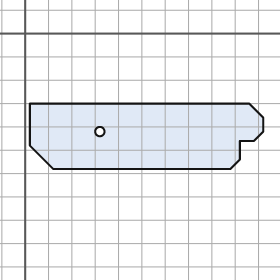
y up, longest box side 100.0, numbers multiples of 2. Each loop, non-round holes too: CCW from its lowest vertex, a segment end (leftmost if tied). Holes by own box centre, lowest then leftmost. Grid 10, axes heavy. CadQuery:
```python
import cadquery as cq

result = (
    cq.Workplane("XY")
    .moveTo(12.0, -58.0)
    .lineTo(88.0, -58.0)
    .lineTo(92.0, -54.0)
    .lineTo(92.0, -46.0)
    .lineTo(98.0, -46.0)
    .lineTo(102.0, -42.0)
    .lineTo(102.0, -36.0)
    .lineTo(96.0, -30.0)
    .lineTo(2.0, -30.0)
    .lineTo(2.0, -48.0)
    .close()
    .moveTo(32.0, -42.0)
    .circle(2.0)
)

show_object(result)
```